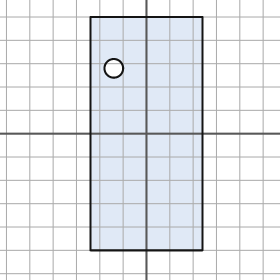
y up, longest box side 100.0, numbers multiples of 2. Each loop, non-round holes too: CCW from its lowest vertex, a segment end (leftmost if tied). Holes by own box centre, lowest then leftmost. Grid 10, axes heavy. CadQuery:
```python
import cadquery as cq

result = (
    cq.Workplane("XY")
    .moveTo(-24.0, -50.0)
    .lineTo(24.0, -50.0)
    .lineTo(24.0, 50.0)
    .lineTo(-24.0, 50.0)
    .close()
    .moveTo(-14.0, 28.0)
    .circle(4.0)
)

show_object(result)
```